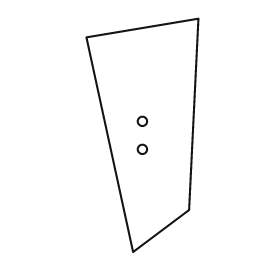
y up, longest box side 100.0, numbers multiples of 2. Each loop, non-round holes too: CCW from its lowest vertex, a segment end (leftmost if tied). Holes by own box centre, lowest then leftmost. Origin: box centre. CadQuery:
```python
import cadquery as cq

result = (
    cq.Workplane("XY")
    .moveTo(-4.0, -50.0)
    .lineTo(20.0, -32.0)
    .lineTo(24.0, 50.0)
    .lineTo(-24.0, 42.0)
    .close()
    .moveTo(0.0, -6.0)
    .circle(2.0)
    .moveTo(0.0, 6.0)
    .circle(2.0)
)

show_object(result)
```